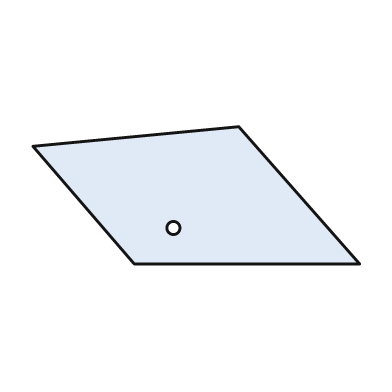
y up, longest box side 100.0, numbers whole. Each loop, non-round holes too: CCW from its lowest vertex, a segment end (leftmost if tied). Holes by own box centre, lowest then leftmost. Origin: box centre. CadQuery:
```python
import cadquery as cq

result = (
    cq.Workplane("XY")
    .moveTo(-19.0, -21.0)
    .lineTo(50.0, -21.0)
    .lineTo(13.0, 21.0)
    .lineTo(-50.0, 15.0)
    .close()
    .moveTo(-7.0, -10.0)
    .circle(2.0)
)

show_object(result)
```